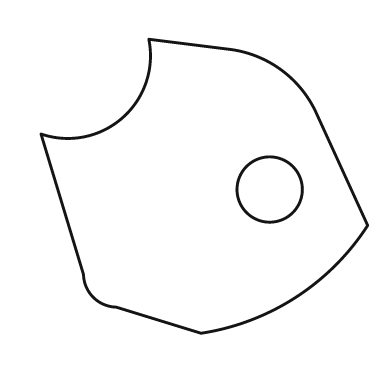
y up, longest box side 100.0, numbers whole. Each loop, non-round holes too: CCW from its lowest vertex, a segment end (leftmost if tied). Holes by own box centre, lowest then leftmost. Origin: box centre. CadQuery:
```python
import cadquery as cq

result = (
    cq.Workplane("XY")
    .moveTo(-1.0, -45.0)
    .threePointArc((28.0, -34.0), (50.0, -12.0))
    .lineTo(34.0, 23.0)
    .threePointArc((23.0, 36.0), (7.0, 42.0))
    .lineTo(-17.0, 45.0)
    .threePointArc((-25.0, 21.0), (-50.0, 16.0))
    .lineTo(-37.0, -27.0)
    .threePointArc((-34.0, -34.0), (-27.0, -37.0))
    .close()
    .moveTo(20.0, -1.0)
    .circle(10.0)
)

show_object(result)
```